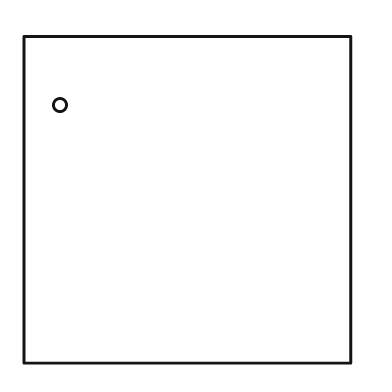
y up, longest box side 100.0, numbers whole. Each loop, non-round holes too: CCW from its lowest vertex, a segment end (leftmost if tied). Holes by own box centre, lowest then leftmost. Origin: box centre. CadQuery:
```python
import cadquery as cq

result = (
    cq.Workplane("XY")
    .moveTo(-50.0, -50.0)
    .lineTo(50.0, -50.0)
    .lineTo(50.0, 50.0)
    .lineTo(-50.0, 50.0)
    .close()
    .moveTo(-39.0, 29.0)
    .circle(2.0)
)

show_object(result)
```